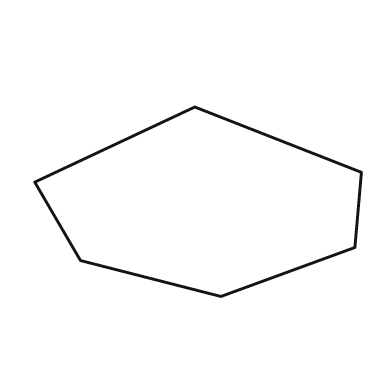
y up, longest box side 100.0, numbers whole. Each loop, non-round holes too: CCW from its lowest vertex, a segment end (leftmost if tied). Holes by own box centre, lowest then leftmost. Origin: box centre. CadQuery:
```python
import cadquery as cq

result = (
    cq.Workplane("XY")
    .moveTo(7.0, -29.0)
    .lineTo(48.0, -14.0)
    .lineTo(50.0, 9.0)
    .lineTo(-1.0, 29.0)
    .lineTo(-50.0, 6.0)
    .lineTo(-36.0, -18.0)
    .close()
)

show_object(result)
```